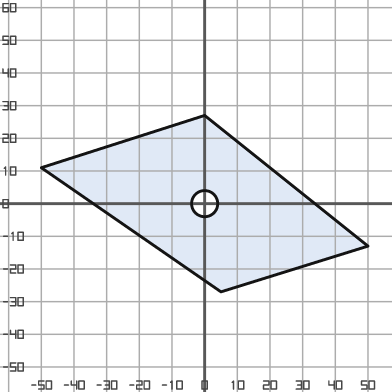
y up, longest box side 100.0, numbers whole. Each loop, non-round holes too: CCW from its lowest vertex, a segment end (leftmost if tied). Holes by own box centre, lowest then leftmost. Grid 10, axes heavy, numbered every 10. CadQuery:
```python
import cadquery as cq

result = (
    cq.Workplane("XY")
    .moveTo(5.0, -27.0)
    .lineTo(50.0, -13.0)
    .lineTo(0.0, 27.0)
    .lineTo(-50.0, 11.0)
    .close()
    .moveTo(0.0, 0.0)
    .circle(4.0)
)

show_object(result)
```